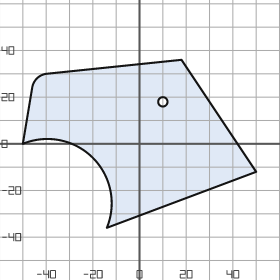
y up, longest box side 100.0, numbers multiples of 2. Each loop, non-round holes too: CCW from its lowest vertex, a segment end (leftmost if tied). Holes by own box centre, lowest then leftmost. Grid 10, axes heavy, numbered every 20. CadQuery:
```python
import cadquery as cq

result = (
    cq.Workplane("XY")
    .moveTo(-14.0, -36.0)
    .lineTo(50.0, -12.0)
    .lineTo(18.0, 36.0)
    .lineTo(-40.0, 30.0)
    .threePointArc((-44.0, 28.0), (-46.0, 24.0))
    .lineTo(-50.0, 0.0)
    .threePointArc((-20.0, -6.0), (-14.0, -36.0))
    .close()
    .moveTo(10.0, 18.0)
    .circle(2.0)
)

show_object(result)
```